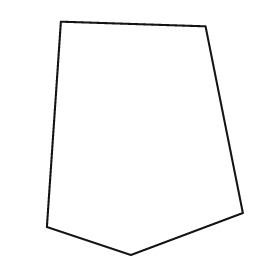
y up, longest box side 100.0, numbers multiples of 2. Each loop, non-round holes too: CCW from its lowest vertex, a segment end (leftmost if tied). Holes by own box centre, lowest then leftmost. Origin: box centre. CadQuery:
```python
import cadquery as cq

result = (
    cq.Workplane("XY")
    .moveTo(-6.0, -50.0)
    .lineTo(42.0, -32.0)
    .lineTo(26.0, 48.0)
    .lineTo(-36.0, 50.0)
    .lineTo(-42.0, -38.0)
    .close()
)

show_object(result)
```